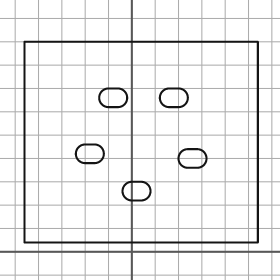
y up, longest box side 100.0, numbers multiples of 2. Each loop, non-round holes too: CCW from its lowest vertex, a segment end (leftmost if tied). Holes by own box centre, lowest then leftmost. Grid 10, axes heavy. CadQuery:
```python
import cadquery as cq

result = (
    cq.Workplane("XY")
    .moveTo(-46.0, 4.0)
    .lineTo(54.0, 4.0)
    .lineTo(54.0, 90.0)
    .lineTo(-46.0, 90.0)
    .close()
    .moveTo(0.0, 22.0)
    .lineTo(4.0, 22.0)
    .threePointArc((8.0, 26.0), (4.0, 30.0))
    .lineTo(0.0, 30.0)
    .threePointArc((-4.0, 26.0), (0.0, 22.0))
    .close()
    .moveTo(24.0, 36.0)
    .lineTo(28.0, 36.0)
    .threePointArc((32.0, 40.0), (28.0, 44.0))
    .lineTo(24.0, 44.0)
    .threePointArc((20.0, 40.0), (24.0, 36.0))
    .close()
    .moveTo(-20.0, 38.0)
    .lineTo(-16.0, 38.0)
    .threePointArc((-12.0, 42.0), (-16.0, 46.0))
    .lineTo(-20.0, 46.0)
    .threePointArc((-24.0, 42.0), (-20.0, 38.0))
    .close()
    .moveTo(-10.0, 62.0)
    .lineTo(-6.0, 62.0)
    .threePointArc((-2.0, 66.0), (-6.0, 70.0))
    .lineTo(-10.0, 70.0)
    .threePointArc((-14.0, 66.0), (-10.0, 62.0))
    .close()
    .moveTo(16.0, 62.0)
    .lineTo(20.0, 62.0)
    .threePointArc((24.0, 66.0), (20.0, 70.0))
    .lineTo(16.0, 70.0)
    .threePointArc((12.0, 66.0), (16.0, 62.0))
    .close()
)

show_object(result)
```